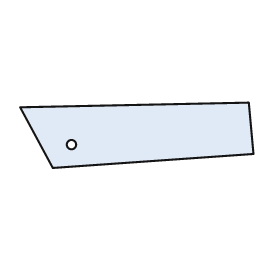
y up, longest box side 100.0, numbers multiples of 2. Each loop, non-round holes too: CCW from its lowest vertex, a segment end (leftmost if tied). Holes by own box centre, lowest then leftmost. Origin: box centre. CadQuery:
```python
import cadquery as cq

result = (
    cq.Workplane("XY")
    .moveTo(-36.0, -14.0)
    .lineTo(50.0, -8.0)
    .lineTo(48.0, 14.0)
    .lineTo(-50.0, 12.0)
    .close()
    .moveTo(-28.0, -4.0)
    .circle(2.0)
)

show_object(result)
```